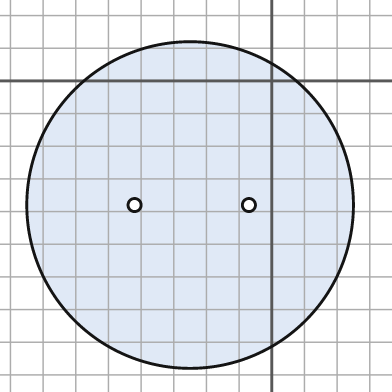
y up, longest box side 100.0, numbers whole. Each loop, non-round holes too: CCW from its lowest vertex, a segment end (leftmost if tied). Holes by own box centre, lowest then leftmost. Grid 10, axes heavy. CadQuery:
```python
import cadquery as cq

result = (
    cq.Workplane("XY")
    .moveTo(-25.0, -38.0)
    .circle(50.0)
    .moveTo(-42.0, -38.0)
    .circle(2.0)
    .moveTo(-7.0, -38.0)
    .circle(2.0)
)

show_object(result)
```